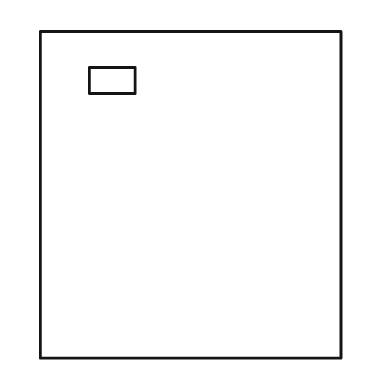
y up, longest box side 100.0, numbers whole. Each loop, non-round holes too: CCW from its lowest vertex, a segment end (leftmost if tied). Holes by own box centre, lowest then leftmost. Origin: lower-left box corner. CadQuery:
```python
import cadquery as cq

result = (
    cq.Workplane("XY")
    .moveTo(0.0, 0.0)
    .lineTo(92.0, 0.0)
    .lineTo(92.0, 100.0)
    .lineTo(0.0, 100.0)
    .close()
    .moveTo(15.0, 81.0)
    .lineTo(29.0, 81.0)
    .lineTo(29.0, 89.0)
    .lineTo(15.0, 89.0)
    .close()
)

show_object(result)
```